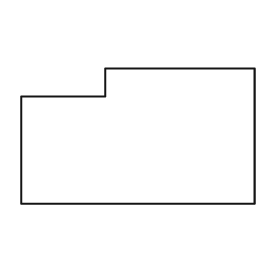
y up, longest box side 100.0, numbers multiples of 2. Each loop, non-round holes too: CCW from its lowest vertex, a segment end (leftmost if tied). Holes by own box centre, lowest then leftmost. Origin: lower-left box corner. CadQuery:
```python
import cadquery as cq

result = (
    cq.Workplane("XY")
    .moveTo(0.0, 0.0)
    .lineTo(100.0, 0.0)
    .lineTo(100.0, 58.0)
    .lineTo(36.0, 58.0)
    .lineTo(36.0, 46.0)
    .lineTo(0.0, 46.0)
    .close()
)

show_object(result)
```